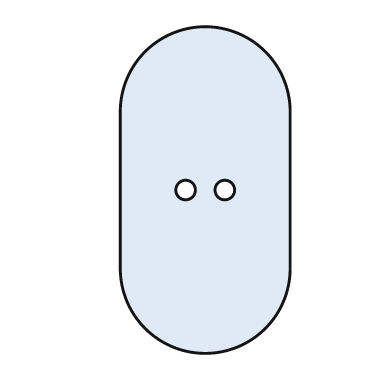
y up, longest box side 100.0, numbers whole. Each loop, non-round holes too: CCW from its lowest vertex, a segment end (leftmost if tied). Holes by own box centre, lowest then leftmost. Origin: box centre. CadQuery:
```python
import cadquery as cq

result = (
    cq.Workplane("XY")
    .moveTo(-26.0, -24.0)
    .threePointArc((0.0, -50.0), (26.0, -24.0))
    .lineTo(26.0, 24.0)
    .threePointArc((0.0, 50.0), (-26.0, 24.0))
    .close()
    .moveTo(-6.0, 0.0)
    .circle(3.0)
    .moveTo(6.0, 0.0)
    .circle(3.0)
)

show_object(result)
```